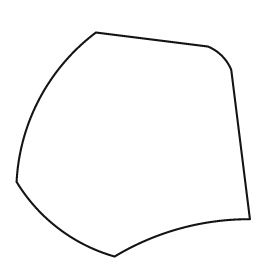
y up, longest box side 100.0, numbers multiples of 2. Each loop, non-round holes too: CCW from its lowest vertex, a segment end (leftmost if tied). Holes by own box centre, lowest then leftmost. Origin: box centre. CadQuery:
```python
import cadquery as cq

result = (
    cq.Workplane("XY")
    .moveTo(-8.0, -48.0)
    .threePointArc((20.0, -36.0), (50.0, -32.0))
    .lineTo(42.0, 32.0)
    .threePointArc((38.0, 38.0), (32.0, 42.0))
    .lineTo(-16.0, 48.0)
    .threePointArc((-40.0, 20.0), (-50.0, -16.0))
    .threePointArc((-32.0, -36.0), (-8.0, -48.0))
    .close()
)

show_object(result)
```